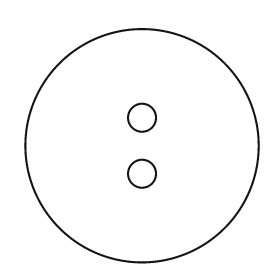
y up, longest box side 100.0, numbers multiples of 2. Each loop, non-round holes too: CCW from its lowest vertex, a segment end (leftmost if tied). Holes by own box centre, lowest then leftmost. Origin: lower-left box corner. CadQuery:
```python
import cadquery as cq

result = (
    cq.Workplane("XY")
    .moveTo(50.0, 50.0)
    .circle(50.0)
    .moveTo(50.0, 38.0)
    .circle(6.0)
    .moveTo(50.0, 62.0)
    .circle(6.0)
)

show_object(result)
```